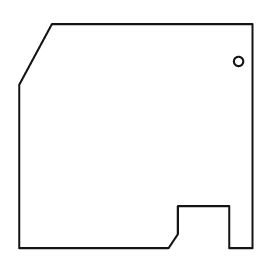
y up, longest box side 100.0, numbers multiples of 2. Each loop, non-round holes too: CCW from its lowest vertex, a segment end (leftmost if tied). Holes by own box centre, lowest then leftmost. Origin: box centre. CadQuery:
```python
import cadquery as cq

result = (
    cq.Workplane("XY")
    .moveTo(-50.0, -48.0)
    .lineTo(14.0, -48.0)
    .lineTo(18.0, -42.0)
    .lineTo(18.0, -30.0)
    .lineTo(40.0, -30.0)
    .lineTo(40.0, -48.0)
    .lineTo(50.0, -48.0)
    .lineTo(50.0, 48.0)
    .lineTo(-36.0, 48.0)
    .lineTo(-50.0, 22.0)
    .close()
    .moveTo(44.0, 32.0)
    .circle(2.0)
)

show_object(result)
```